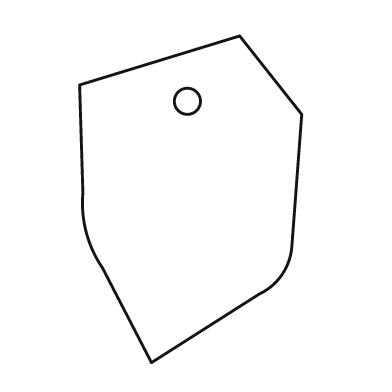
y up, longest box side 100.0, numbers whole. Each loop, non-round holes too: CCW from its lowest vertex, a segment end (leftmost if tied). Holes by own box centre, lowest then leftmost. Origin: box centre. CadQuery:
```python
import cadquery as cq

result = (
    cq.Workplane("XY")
    .moveTo(-12.0, -50.0)
    .lineTo(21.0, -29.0)
    .threePointArc((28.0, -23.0), (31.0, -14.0))
    .lineTo(34.0, 26.0)
    .lineTo(15.0, 50.0)
    .lineTo(-34.0, 35.0)
    .lineTo(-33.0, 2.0)
    .threePointArc((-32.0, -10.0), (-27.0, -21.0))
    .close()
    .moveTo(-1.0, 30.0)
    .circle(4.0)
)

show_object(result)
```